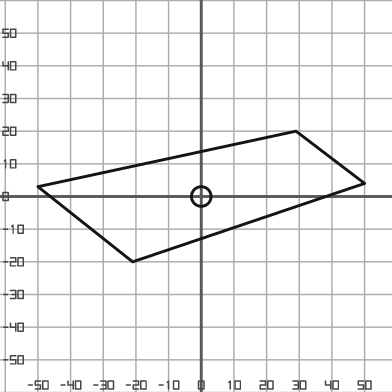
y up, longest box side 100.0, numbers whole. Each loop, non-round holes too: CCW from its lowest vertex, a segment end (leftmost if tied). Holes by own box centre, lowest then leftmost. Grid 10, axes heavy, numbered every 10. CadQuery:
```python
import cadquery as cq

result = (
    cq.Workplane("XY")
    .moveTo(-21.0, -20.0)
    .lineTo(50.0, 4.0)
    .lineTo(29.0, 20.0)
    .lineTo(-50.0, 3.0)
    .close()
    .moveTo(0.0, 0.0)
    .circle(3.0)
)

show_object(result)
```